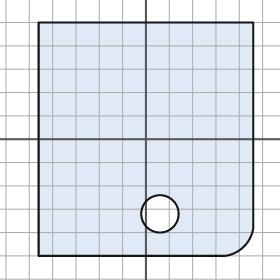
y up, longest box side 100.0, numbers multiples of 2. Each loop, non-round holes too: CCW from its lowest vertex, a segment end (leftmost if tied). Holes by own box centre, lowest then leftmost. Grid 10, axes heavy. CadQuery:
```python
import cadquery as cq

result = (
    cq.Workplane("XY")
    .moveTo(-46.0, -50.0)
    .lineTo(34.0, -50.0)
    .threePointArc((42.0, -46.0), (46.0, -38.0))
    .lineTo(46.0, 50.0)
    .lineTo(-46.0, 50.0)
    .close()
    .moveTo(6.0, -32.0)
    .circle(8.0)
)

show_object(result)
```